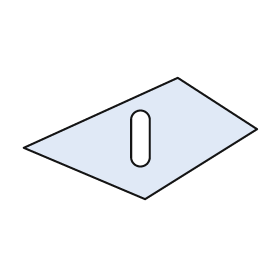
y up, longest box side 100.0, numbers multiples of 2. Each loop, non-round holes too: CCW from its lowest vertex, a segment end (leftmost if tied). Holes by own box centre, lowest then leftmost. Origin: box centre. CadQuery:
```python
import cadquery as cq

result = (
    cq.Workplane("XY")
    .moveTo(2.0, -26.0)
    .lineTo(50.0, 4.0)
    .lineTo(16.0, 26.0)
    .lineTo(-50.0, -4.0)
    .close()
    .moveTo(-4.0, -8.0)
    .threePointArc((0.0, -12.0), (4.0, -8.0))
    .lineTo(4.0, 8.0)
    .threePointArc((0.0, 12.0), (-4.0, 8.0))
    .close()
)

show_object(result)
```